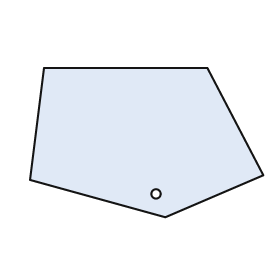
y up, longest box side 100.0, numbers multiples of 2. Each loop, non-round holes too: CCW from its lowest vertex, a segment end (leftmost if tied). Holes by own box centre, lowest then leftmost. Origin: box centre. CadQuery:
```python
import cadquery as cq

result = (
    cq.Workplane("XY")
    .moveTo(8.0, -32.0)
    .lineTo(50.0, -14.0)
    .lineTo(26.0, 32.0)
    .lineTo(-44.0, 32.0)
    .lineTo(-50.0, -16.0)
    .close()
    .moveTo(4.0, -22.0)
    .circle(2.0)
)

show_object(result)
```